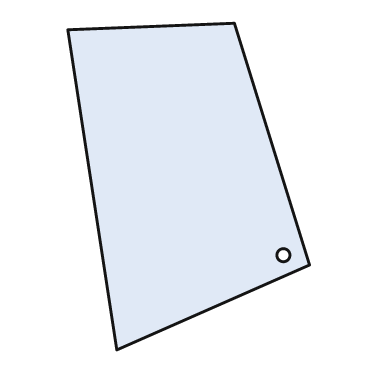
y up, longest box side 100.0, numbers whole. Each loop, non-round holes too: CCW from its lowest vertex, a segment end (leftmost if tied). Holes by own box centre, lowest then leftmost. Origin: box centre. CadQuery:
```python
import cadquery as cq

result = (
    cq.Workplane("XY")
    .moveTo(-22.0, -50.0)
    .lineTo(37.0, -24.0)
    .lineTo(14.0, 50.0)
    .lineTo(-37.0, 48.0)
    .close()
    .moveTo(29.0, -21.0)
    .circle(2.0)
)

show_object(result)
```